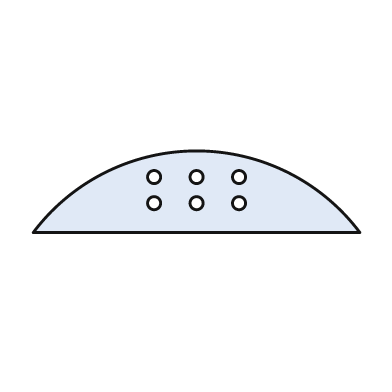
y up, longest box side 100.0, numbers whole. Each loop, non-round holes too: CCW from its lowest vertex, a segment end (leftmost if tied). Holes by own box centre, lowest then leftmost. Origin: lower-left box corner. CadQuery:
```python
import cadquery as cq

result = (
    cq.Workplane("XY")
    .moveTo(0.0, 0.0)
    .lineTo(100.0, 0.0)
    .threePointArc((50.0, 25.0), (0.0, 0.0))
    .close()
    .moveTo(37.0, 9.0)
    .circle(2.0)
    .moveTo(50.0, 9.0)
    .circle(2.0)
    .moveTo(63.0, 9.0)
    .circle(2.0)
    .moveTo(37.0, 17.0)
    .circle(2.0)
    .moveTo(50.0, 17.0)
    .circle(2.0)
    .moveTo(63.0, 17.0)
    .circle(2.0)
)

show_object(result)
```